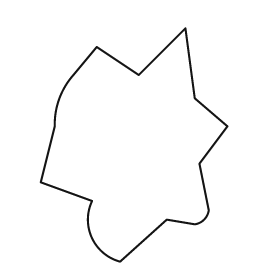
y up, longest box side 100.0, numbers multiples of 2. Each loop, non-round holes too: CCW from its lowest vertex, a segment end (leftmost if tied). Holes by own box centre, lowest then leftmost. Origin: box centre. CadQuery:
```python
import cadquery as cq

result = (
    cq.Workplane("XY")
    .moveTo(-6.0, -50.0)
    .lineTo(14.0, -32.0)
    .lineTo(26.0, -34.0)
    .threePointArc((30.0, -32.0), (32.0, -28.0))
    .lineTo(28.0, -8.0)
    .lineTo(40.0, 8.0)
    .lineTo(26.0, 20.0)
    .lineTo(22.0, 50.0)
    .lineTo(2.0, 30.0)
    .lineTo(-16.0, 42.0)
    .lineTo(-26.0, 30.0)
    .threePointArc((-32.0, 20.0), (-34.0, 8.0))
    .lineTo(-40.0, -16.0)
    .lineTo(-18.0, -24.0)
    .threePointArc((-18.0, -40.0), (-6.0, -50.0))
    .close()
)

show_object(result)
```